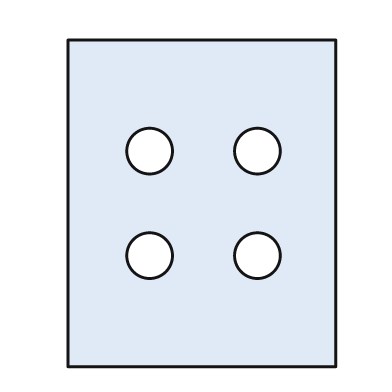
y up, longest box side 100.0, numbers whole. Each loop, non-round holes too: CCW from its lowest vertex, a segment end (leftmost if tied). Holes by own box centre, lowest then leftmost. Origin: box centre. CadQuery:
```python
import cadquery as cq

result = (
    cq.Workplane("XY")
    .moveTo(-41.0, -50.0)
    .lineTo(41.0, -50.0)
    .lineTo(41.0, 50.0)
    .lineTo(-41.0, 50.0)
    .close()
    .moveTo(-16.0, -16.0)
    .circle(7.0)
    .moveTo(17.0, -16.0)
    .circle(7.0)
    .moveTo(-16.0, 16.0)
    .circle(7.0)
    .moveTo(17.0, 16.0)
    .circle(7.0)
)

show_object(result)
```